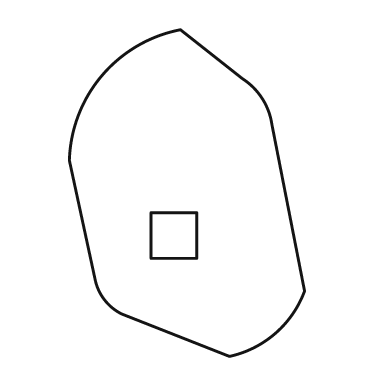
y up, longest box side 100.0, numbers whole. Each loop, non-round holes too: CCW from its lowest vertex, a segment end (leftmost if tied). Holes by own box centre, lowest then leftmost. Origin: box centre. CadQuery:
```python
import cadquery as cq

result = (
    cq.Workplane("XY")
    .moveTo(13.0, -50.0)
    .threePointArc((27.0, -43.0), (36.0, -30.0))
    .lineTo(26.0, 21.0)
    .threePointArc((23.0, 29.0), (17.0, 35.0))
    .lineTo(-2.0, 50.0)
    .threePointArc((-26.0, 36.0), (-36.0, 10.0))
    .lineTo(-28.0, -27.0)
    .threePointArc((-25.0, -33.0), (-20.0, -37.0))
    .close()
    .moveTo(-11.0, -20.0)
    .lineTo(3.0, -20.0)
    .lineTo(3.0, -6.0)
    .lineTo(-11.0, -6.0)
    .close()
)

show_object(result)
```